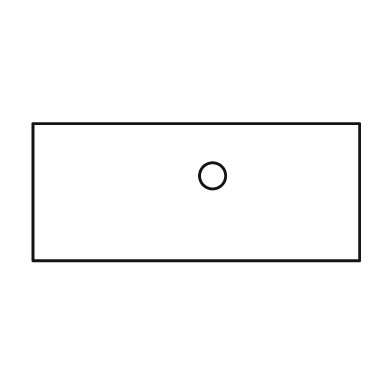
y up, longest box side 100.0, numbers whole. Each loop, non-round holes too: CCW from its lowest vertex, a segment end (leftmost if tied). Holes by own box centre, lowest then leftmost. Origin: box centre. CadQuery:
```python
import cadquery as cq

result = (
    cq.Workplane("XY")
    .moveTo(-50.0, -21.0)
    .lineTo(50.0, -21.0)
    .lineTo(50.0, 21.0)
    .lineTo(-50.0, 21.0)
    .close()
    .moveTo(5.0, 5.0)
    .circle(4.0)
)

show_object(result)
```